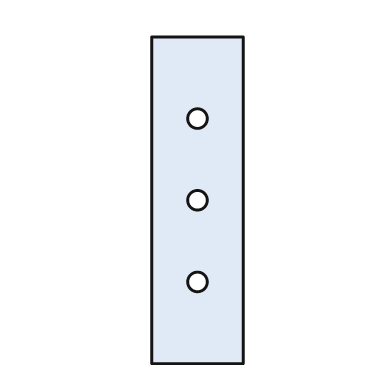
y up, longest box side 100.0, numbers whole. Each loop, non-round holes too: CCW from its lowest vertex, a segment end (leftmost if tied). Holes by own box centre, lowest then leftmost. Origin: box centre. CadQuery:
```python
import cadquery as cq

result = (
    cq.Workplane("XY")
    .moveTo(-14.0, -50.0)
    .lineTo(14.0, -50.0)
    .lineTo(14.0, 50.0)
    .lineTo(-14.0, 50.0)
    .close()
    .moveTo(0.0, -25.0)
    .circle(3.0)
    .moveTo(0.0, 0.0)
    .circle(3.0)
    .moveTo(0.0, 25.0)
    .circle(3.0)
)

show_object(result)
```